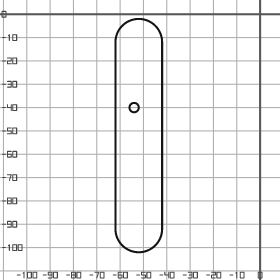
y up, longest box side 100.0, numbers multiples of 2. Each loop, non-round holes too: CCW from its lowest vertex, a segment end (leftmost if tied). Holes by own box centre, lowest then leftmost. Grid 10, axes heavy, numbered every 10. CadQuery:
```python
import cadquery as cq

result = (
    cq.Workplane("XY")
    .moveTo(-62.0, -92.0)
    .threePointArc((-52.0, -102.0), (-42.0, -92.0))
    .lineTo(-42.0, -12.0)
    .threePointArc((-52.0, -2.0), (-62.0, -12.0))
    .close()
    .moveTo(-54.0, -40.0)
    .circle(2.0)
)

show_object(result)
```